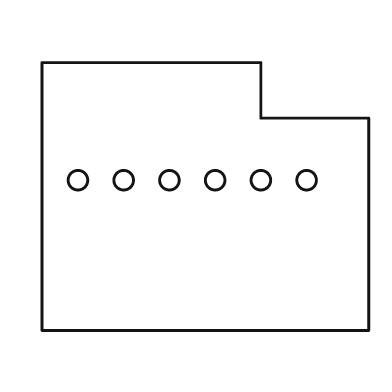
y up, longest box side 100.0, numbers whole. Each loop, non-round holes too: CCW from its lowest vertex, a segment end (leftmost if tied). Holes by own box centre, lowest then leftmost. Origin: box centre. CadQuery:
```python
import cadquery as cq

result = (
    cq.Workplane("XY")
    .moveTo(-50.0, -41.0)
    .lineTo(50.0, -41.0)
    .lineTo(50.0, 24.0)
    .lineTo(17.0, 24.0)
    .lineTo(17.0, 41.0)
    .lineTo(-50.0, 41.0)
    .close()
    .moveTo(-39.0, 5.0)
    .circle(3.0)
    .moveTo(-25.0, 5.0)
    .circle(3.0)
    .moveTo(-11.0, 5.0)
    .circle(3.0)
    .moveTo(3.0, 5.0)
    .circle(3.0)
    .moveTo(17.0, 5.0)
    .circle(3.0)
    .moveTo(31.0, 5.0)
    .circle(3.0)
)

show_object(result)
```